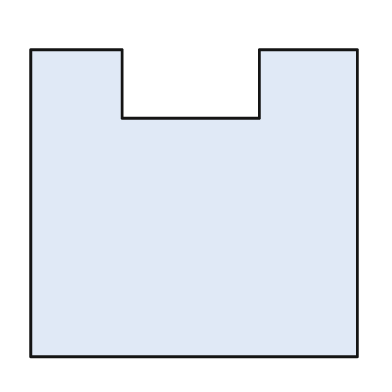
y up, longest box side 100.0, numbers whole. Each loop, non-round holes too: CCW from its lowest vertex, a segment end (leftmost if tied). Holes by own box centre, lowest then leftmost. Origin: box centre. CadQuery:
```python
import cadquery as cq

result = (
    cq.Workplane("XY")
    .moveTo(-50.0, -47.0)
    .lineTo(50.0, -47.0)
    .lineTo(50.0, 47.0)
    .lineTo(20.0, 47.0)
    .lineTo(20.0, 26.0)
    .lineTo(-22.0, 26.0)
    .lineTo(-22.0, 47.0)
    .lineTo(-50.0, 47.0)
    .close()
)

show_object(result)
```